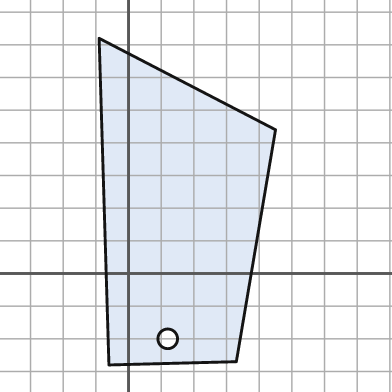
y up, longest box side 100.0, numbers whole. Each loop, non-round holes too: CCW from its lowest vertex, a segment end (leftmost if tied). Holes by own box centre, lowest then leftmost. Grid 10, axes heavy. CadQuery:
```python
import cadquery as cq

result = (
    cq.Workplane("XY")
    .moveTo(-6.0, -28.0)
    .lineTo(33.0, -27.0)
    .lineTo(45.0, 44.0)
    .lineTo(-9.0, 72.0)
    .close()
    .moveTo(12.0, -20.0)
    .circle(3.0)
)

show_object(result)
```